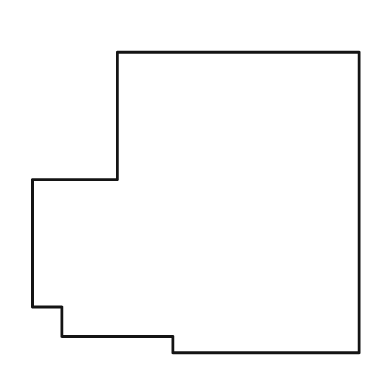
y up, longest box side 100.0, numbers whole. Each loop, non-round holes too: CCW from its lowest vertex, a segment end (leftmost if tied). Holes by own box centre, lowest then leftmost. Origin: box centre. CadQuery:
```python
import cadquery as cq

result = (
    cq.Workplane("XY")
    .moveTo(-7.0, -46.0)
    .lineTo(50.0, -46.0)
    .lineTo(50.0, 46.0)
    .lineTo(-24.0, 46.0)
    .lineTo(-24.0, 7.0)
    .lineTo(-50.0, 7.0)
    .lineTo(-50.0, -32.0)
    .lineTo(-41.0, -32.0)
    .lineTo(-41.0, -41.0)
    .lineTo(-7.0, -41.0)
    .close()
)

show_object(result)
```